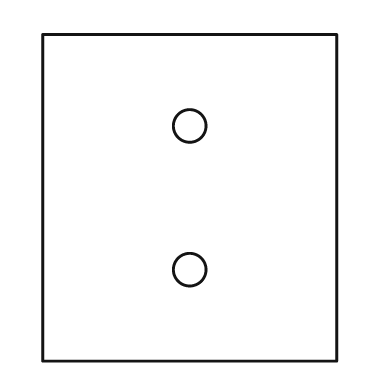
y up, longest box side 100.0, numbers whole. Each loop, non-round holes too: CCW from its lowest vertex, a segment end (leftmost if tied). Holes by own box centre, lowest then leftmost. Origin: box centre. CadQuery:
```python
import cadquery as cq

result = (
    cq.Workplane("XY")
    .moveTo(-45.0, -50.0)
    .lineTo(45.0, -50.0)
    .lineTo(45.0, 50.0)
    .lineTo(-45.0, 50.0)
    .close()
    .moveTo(0.0, -22.0)
    .circle(5.0)
    .moveTo(0.0, 22.0)
    .circle(5.0)
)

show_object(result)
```